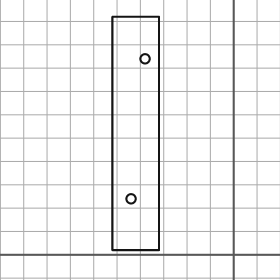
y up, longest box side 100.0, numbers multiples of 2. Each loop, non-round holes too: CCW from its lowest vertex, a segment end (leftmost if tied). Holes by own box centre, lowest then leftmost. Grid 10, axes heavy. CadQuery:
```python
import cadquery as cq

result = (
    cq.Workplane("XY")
    .moveTo(-52.0, 2.0)
    .lineTo(-32.0, 2.0)
    .lineTo(-32.0, 102.0)
    .lineTo(-52.0, 102.0)
    .close()
    .moveTo(-44.0, 24.0)
    .circle(2.0)
    .moveTo(-38.0, 84.0)
    .circle(2.0)
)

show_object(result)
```